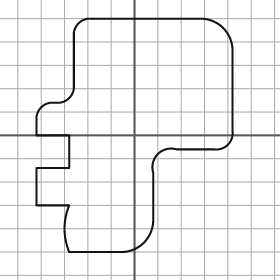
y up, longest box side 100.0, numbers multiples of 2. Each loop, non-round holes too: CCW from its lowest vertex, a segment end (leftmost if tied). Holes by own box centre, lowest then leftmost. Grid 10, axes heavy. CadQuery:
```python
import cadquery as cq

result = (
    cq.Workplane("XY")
    .moveTo(-28.0, -50.0)
    .lineTo(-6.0, -50.0)
    .threePointArc((4.0, -46.0), (8.0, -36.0))
    .lineTo(8.0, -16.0)
    .threePointArc((10.0, -8.0), (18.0, -6.0))
    .lineTo(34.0, -6.0)
    .threePointArc((40.0, -4.0), (42.0, 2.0))
    .lineTo(42.0, 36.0)
    .threePointArc((38.0, 46.0), (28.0, 50.0))
    .lineTo(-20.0, 50.0)
    .threePointArc((-24.0, 48.0), (-26.0, 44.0))
    .lineTo(-26.0, 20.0)
    .threePointArc((-28.0, 16.0), (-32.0, 14.0))
    .lineTo(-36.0, 14.0)
    .threePointArc((-40.0, 12.0), (-42.0, 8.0))
    .lineTo(-42.0, 0.0)
    .lineTo(-28.0, 0.0)
    .lineTo(-28.0, -14.0)
    .lineTo(-42.0, -14.0)
    .lineTo(-42.0, -30.0)
    .lineTo(-28.0, -30.0)
    .threePointArc((-30.0, -40.0), (-28.0, -50.0))
    .close()
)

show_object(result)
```